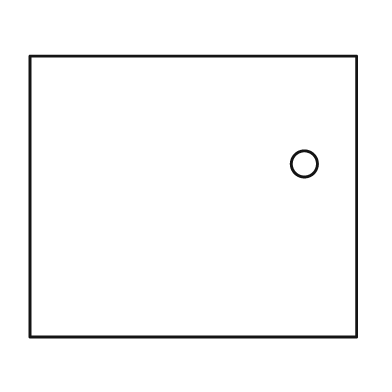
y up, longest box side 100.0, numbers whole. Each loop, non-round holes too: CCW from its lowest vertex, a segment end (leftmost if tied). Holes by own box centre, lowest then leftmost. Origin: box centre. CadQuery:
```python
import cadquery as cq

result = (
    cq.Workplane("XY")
    .moveTo(-50.0, -43.0)
    .lineTo(50.0, -43.0)
    .lineTo(50.0, 43.0)
    .lineTo(-50.0, 43.0)
    .close()
    .moveTo(34.0, 10.0)
    .circle(4.0)
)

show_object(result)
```